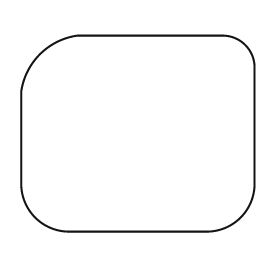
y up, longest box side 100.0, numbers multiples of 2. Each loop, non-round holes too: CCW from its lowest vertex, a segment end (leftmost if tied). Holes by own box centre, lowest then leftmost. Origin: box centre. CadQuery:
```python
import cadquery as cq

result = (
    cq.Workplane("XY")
    .moveTo(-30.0, -42.0)
    .lineTo(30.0, -42.0)
    .threePointArc((44.0, -36.0), (50.0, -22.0))
    .lineTo(50.0, 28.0)
    .threePointArc((46.0, 38.0), (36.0, 42.0))
    .lineTo(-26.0, 42.0)
    .threePointArc((-42.0, 34.0), (-50.0, 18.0))
    .lineTo(-50.0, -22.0)
    .threePointArc((-44.0, -36.0), (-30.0, -42.0))
    .close()
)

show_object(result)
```